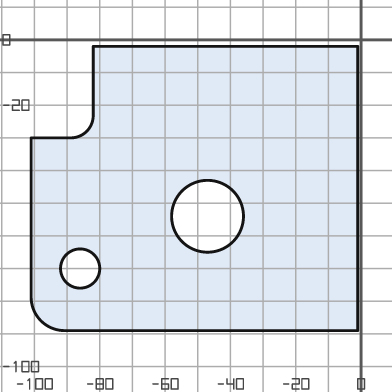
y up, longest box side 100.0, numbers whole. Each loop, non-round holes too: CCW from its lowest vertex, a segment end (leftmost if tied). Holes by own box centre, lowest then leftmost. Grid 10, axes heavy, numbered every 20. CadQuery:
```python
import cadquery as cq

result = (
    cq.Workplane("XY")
    .moveTo(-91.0, -89.0)
    .lineTo(-1.0, -89.0)
    .lineTo(-1.0, -2.0)
    .lineTo(-82.0, -2.0)
    .lineTo(-82.0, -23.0)
    .threePointArc((-84.0, -28.0), (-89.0, -30.0))
    .lineTo(-101.0, -30.0)
    .lineTo(-101.0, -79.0)
    .threePointArc((-98.0, -86.0), (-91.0, -89.0))
    .close()
    .moveTo(-86.0, -70.0)
    .circle(6.0)
    .moveTo(-47.0, -54.0)
    .circle(11.0)
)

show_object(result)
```